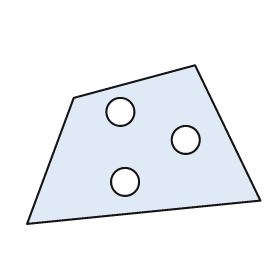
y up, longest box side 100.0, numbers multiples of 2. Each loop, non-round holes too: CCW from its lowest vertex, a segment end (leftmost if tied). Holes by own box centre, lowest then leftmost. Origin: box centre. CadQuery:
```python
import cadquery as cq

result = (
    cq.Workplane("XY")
    .moveTo(-50.0, -34.0)
    .lineTo(50.0, -24.0)
    .lineTo(22.0, 34.0)
    .lineTo(-30.0, 20.0)
    .close()
    .moveTo(-8.0, -16.0)
    .circle(6.0)
    .moveTo(18.0, 2.0)
    .circle(6.0)
    .moveTo(-10.0, 14.0)
    .circle(6.0)
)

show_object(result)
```